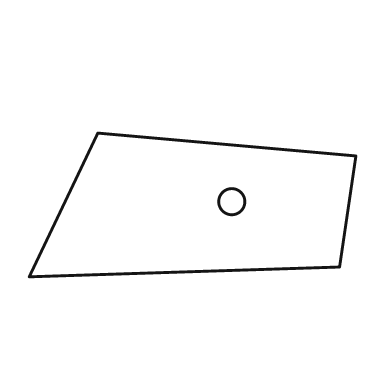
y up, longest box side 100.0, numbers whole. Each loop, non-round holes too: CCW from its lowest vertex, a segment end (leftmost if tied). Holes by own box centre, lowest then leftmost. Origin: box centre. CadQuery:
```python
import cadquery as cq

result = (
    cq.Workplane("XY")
    .moveTo(-50.0, -22.0)
    .lineTo(45.0, -19.0)
    .lineTo(50.0, 15.0)
    .lineTo(-29.0, 22.0)
    .close()
    .moveTo(12.0, 1.0)
    .circle(4.0)
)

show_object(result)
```